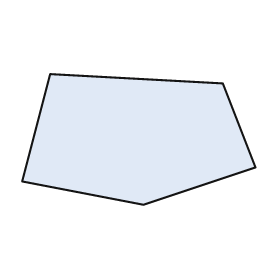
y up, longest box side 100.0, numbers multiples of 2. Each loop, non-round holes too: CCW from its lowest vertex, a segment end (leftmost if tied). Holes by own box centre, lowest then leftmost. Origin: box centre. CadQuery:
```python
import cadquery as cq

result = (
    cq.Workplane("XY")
    .moveTo(2.0, -28.0)
    .lineTo(50.0, -12.0)
    .lineTo(36.0, 24.0)
    .lineTo(-38.0, 28.0)
    .lineTo(-50.0, -18.0)
    .close()
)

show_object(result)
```